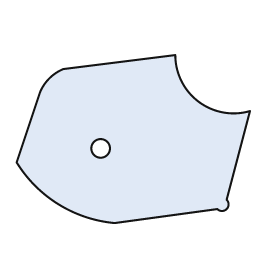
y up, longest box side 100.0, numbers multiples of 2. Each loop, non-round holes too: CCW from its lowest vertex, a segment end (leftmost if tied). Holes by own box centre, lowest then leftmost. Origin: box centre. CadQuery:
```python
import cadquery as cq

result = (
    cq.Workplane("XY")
    .moveTo(-8.0, -36.0)
    .lineTo(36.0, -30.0)
    .threePointArc((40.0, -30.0), (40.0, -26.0))
    .lineTo(50.0, 12.0)
    .threePointArc((28.0, 16.0), (18.0, 36.0))
    .lineTo(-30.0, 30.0)
    .threePointArc((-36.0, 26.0), (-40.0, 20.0))
    .lineTo(-50.0, -10.0)
    .threePointArc((-32.0, -28.0), (-8.0, -36.0))
    .close()
    .moveTo(-14.0, -4.0)
    .circle(4.0)
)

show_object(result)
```